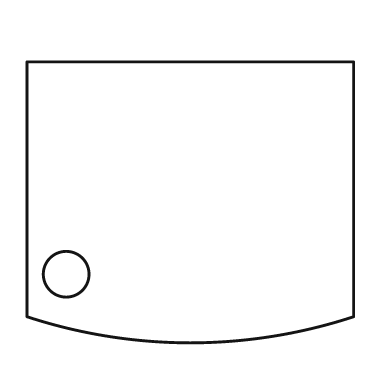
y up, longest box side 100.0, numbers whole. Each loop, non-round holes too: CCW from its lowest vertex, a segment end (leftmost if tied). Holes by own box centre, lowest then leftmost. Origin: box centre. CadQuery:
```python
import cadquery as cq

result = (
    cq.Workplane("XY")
    .moveTo(-50.0, -35.0)
    .threePointArc((0.0, -43.0), (50.0, -35.0))
    .lineTo(50.0, 43.0)
    .lineTo(-50.0, 43.0)
    .close()
    .moveTo(-38.0, -22.0)
    .circle(7.0)
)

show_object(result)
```